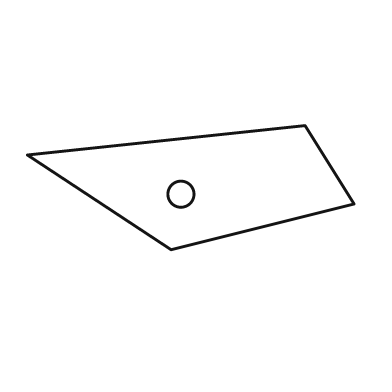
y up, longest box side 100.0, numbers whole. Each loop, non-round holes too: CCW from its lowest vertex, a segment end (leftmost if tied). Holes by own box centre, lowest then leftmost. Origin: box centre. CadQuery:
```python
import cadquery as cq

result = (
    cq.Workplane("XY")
    .moveTo(-6.0, -19.0)
    .lineTo(50.0, -5.0)
    .lineTo(35.0, 19.0)
    .lineTo(-50.0, 10.0)
    .close()
    .moveTo(-3.0, -2.0)
    .circle(4.0)
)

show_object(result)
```